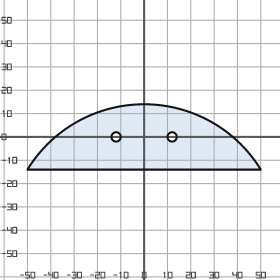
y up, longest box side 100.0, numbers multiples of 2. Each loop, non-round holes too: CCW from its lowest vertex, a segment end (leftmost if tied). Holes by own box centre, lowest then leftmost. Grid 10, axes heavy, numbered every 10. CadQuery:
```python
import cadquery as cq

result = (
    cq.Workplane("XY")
    .moveTo(-50.0, -14.0)
    .lineTo(50.0, -14.0)
    .threePointArc((0.0, 14.0), (-50.0, -14.0))
    .close()
    .moveTo(-12.0, 0.0)
    .circle(2.0)
    .moveTo(12.0, 0.0)
    .circle(2.0)
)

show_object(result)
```